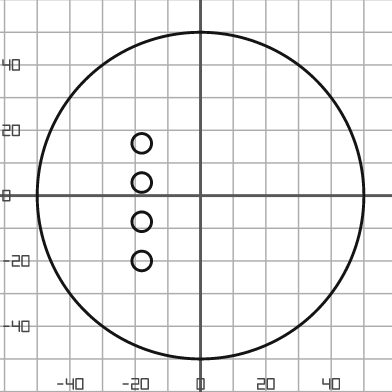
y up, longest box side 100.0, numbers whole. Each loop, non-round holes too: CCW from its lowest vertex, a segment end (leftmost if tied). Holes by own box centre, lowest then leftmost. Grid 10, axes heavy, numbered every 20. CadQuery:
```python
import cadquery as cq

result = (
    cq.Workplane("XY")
    .moveTo(0.0, 0.0)
    .circle(50.0)
    .moveTo(-18.0, -20.0)
    .circle(3.0)
    .moveTo(-18.0, -8.0)
    .circle(3.0)
    .moveTo(-18.0, 4.0)
    .circle(3.0)
    .moveTo(-18.0, 16.0)
    .circle(3.0)
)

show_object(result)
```